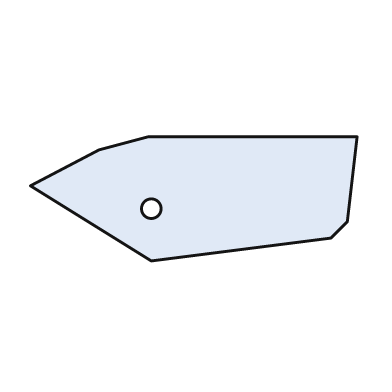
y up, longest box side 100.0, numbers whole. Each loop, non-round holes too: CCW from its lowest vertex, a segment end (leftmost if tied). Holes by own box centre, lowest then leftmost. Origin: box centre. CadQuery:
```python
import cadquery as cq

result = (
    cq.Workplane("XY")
    .moveTo(-13.0, -19.0)
    .lineTo(42.0, -12.0)
    .lineTo(47.0, -7.0)
    .lineTo(50.0, 19.0)
    .lineTo(-14.0, 19.0)
    .lineTo(-29.0, 15.0)
    .lineTo(-50.0, 4.0)
    .close()
    .moveTo(-13.0, -3.0)
    .circle(3.0)
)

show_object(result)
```